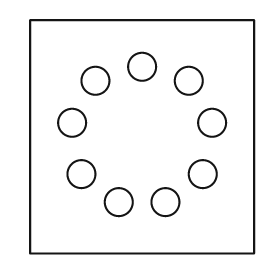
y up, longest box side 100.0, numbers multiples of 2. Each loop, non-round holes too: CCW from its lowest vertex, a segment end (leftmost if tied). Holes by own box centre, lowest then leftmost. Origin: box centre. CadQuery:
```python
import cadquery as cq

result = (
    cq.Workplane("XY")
    .moveTo(-48.0, -50.0)
    .lineTo(48.0, -50.0)
    .lineTo(48.0, 50.0)
    .lineTo(-48.0, 50.0)
    .close()
    .moveTo(-10.0, -28.0)
    .circle(6.0)
    .moveTo(10.0, -28.0)
    .circle(6.0)
    .moveTo(-26.0, -16.0)
    .circle(6.0)
    .moveTo(26.0, -16.0)
    .circle(6.0)
    .moveTo(-30.0, 6.0)
    .circle(6.0)
    .moveTo(30.0, 6.0)
    .circle(6.0)
    .moveTo(-20.0, 24.0)
    .circle(6.0)
    .moveTo(20.0, 24.0)
    .circle(6.0)
    .moveTo(0.0, 30.0)
    .circle(6.0)
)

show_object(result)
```